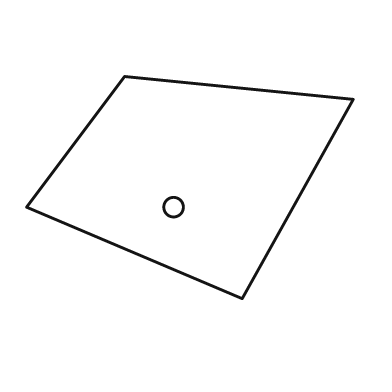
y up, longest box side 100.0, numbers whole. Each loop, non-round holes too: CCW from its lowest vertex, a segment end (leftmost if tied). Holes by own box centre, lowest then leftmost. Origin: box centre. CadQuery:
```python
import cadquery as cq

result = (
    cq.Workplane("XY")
    .moveTo(16.0, -34.0)
    .lineTo(50.0, 27.0)
    .lineTo(-20.0, 34.0)
    .lineTo(-50.0, -6.0)
    .close()
    .moveTo(-5.0, -6.0)
    .circle(3.0)
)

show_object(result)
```